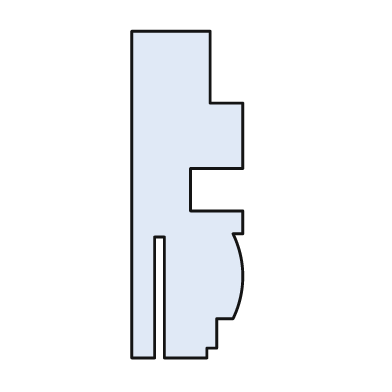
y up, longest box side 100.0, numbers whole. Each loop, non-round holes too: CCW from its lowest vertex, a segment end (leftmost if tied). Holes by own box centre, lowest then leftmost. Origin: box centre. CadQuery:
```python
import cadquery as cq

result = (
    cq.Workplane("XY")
    .moveTo(-17.0, -50.0)
    .lineTo(-10.0, -50.0)
    .lineTo(-10.0, -13.0)
    .lineTo(-7.0, -13.0)
    .lineTo(-7.0, -50.0)
    .lineTo(6.0, -50.0)
    .lineTo(6.0, -47.0)
    .lineTo(9.0, -47.0)
    .lineTo(9.0, -38.0)
    .lineTo(14.0, -38.0)
    .threePointArc((17.0, -25.0), (14.0, -12.0))
    .lineTo(17.0, -12.0)
    .lineTo(17.0, -5.0)
    .lineTo(1.0, -5.0)
    .lineTo(1.0, 8.0)
    .lineTo(17.0, 8.0)
    .lineTo(17.0, 28.0)
    .lineTo(7.0, 28.0)
    .lineTo(7.0, 50.0)
    .lineTo(-17.0, 50.0)
    .close()
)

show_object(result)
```